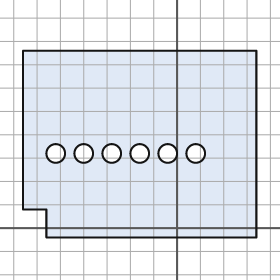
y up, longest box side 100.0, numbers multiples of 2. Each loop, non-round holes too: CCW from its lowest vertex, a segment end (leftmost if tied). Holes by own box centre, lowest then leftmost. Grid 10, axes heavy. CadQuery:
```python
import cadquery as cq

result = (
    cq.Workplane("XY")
    .moveTo(-56.0, -4.0)
    .lineTo(34.0, -4.0)
    .lineTo(34.0, 76.0)
    .lineTo(-66.0, 76.0)
    .lineTo(-66.0, 8.0)
    .lineTo(-56.0, 8.0)
    .close()
    .moveTo(-52.0, 32.0)
    .circle(4.0)
    .moveTo(-40.0, 32.0)
    .circle(4.0)
    .moveTo(-28.0, 32.0)
    .circle(4.0)
    .moveTo(-16.0, 32.0)
    .circle(4.0)
    .moveTo(-4.0, 32.0)
    .circle(4.0)
    .moveTo(8.0, 32.0)
    .circle(4.0)
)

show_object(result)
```